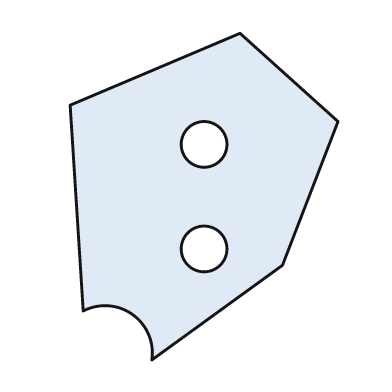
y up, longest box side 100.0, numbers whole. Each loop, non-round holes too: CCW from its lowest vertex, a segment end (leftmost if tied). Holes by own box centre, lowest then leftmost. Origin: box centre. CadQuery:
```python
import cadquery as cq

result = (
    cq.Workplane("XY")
    .moveTo(-16.0, -50.0)
    .lineTo(24.0, -21.0)
    .lineTo(41.0, 23.0)
    .lineTo(11.0, 50.0)
    .lineTo(-41.0, 28.0)
    .lineTo(-37.0, -35.0)
    .threePointArc((-22.0, -36.0), (-16.0, -50.0))
    .close()
    .moveTo(0.0, -16.0)
    .circle(7.0)
    .moveTo(0.0, 16.0)
    .circle(7.0)
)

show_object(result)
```